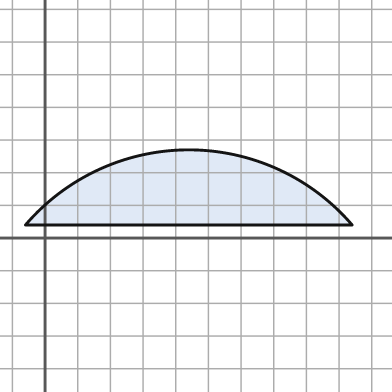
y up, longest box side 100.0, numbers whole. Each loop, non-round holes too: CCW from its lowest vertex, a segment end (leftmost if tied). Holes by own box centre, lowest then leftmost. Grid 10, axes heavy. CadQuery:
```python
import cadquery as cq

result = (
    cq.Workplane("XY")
    .moveTo(-6.0, 4.0)
    .lineTo(94.0, 4.0)
    .threePointArc((44.0, 27.0), (-6.0, 4.0))
    .close()
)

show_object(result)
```